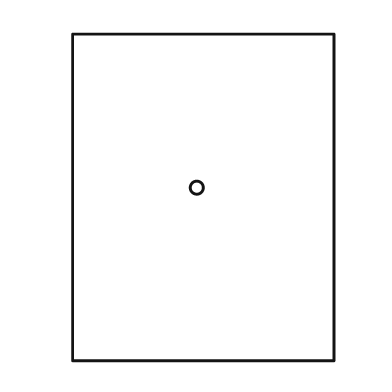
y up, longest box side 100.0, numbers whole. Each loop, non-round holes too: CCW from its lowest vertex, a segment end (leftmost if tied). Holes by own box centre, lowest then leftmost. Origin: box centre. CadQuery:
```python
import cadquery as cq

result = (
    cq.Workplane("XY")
    .moveTo(-40.0, -50.0)
    .lineTo(40.0, -50.0)
    .lineTo(40.0, 50.0)
    .lineTo(-40.0, 50.0)
    .close()
    .moveTo(-2.0, 3.0)
    .circle(2.0)
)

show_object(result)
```